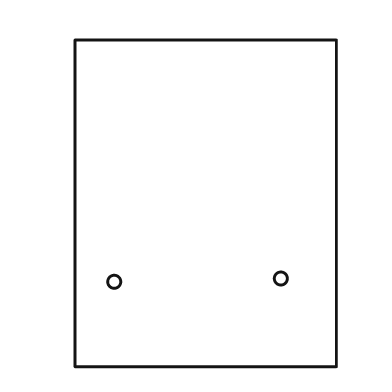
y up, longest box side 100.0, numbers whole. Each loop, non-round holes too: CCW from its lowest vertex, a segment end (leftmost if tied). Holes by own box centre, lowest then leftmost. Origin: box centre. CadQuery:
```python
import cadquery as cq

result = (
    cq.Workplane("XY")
    .moveTo(-40.0, -50.0)
    .lineTo(40.0, -50.0)
    .lineTo(40.0, 50.0)
    .lineTo(-40.0, 50.0)
    .close()
    .moveTo(-28.0, -24.0)
    .circle(2.0)
    .moveTo(23.0, -23.0)
    .circle(2.0)
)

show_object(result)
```